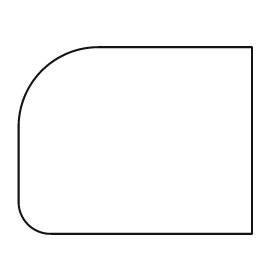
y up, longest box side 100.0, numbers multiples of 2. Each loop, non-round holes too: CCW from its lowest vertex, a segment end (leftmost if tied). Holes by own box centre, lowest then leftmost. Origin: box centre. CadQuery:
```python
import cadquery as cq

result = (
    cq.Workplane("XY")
    .moveTo(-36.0, -40.0)
    .lineTo(50.0, -40.0)
    .lineTo(50.0, 40.0)
    .lineTo(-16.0, 40.0)
    .threePointArc((-40.0, 30.0), (-50.0, 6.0))
    .lineTo(-50.0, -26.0)
    .threePointArc((-46.0, -36.0), (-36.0, -40.0))
    .close()
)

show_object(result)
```